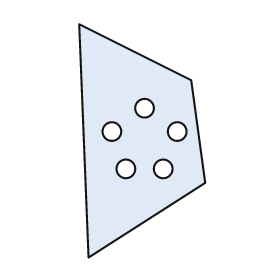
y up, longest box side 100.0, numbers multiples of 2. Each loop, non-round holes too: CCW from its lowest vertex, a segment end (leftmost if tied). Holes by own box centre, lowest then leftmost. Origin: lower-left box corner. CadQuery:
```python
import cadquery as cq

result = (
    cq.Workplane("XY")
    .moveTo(4.0, 0.0)
    .lineTo(54.0, 32.0)
    .lineTo(48.0, 76.0)
    .lineTo(0.0, 100.0)
    .close()
    .moveTo(20.0, 38.0)
    .circle(4.0)
    .moveTo(36.0, 38.0)
    .circle(4.0)
    .moveTo(14.0, 54.0)
    .circle(4.0)
    .moveTo(42.0, 54.0)
    .circle(4.0)
    .moveTo(28.0, 64.0)
    .circle(4.0)
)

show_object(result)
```